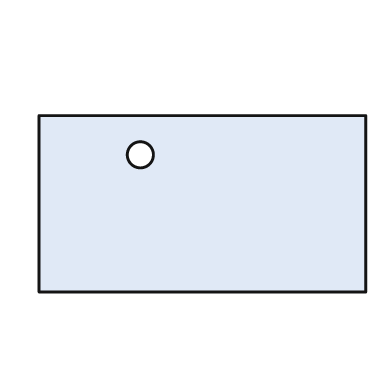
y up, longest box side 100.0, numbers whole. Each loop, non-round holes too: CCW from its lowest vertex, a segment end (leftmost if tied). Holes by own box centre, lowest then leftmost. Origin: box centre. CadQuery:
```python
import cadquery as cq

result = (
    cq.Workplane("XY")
    .moveTo(-50.0, -27.0)
    .lineTo(50.0, -27.0)
    .lineTo(50.0, 27.0)
    .lineTo(-50.0, 27.0)
    .close()
    .moveTo(-19.0, 15.0)
    .circle(4.0)
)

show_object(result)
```